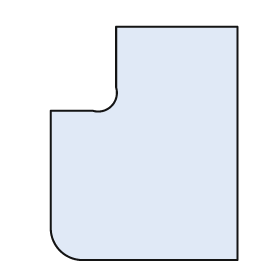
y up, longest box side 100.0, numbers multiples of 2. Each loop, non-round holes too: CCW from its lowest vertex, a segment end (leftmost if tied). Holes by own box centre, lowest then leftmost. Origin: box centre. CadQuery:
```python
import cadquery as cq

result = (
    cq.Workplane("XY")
    .moveTo(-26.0, -50.0)
    .lineTo(40.0, -50.0)
    .lineTo(40.0, 50.0)
    .lineTo(-12.0, 50.0)
    .lineTo(-12.0, 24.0)
    .threePointArc((-14.0, 16.0), (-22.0, 14.0))
    .lineTo(-40.0, 14.0)
    .lineTo(-40.0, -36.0)
    .threePointArc((-36.0, -46.0), (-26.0, -50.0))
    .close()
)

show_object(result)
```